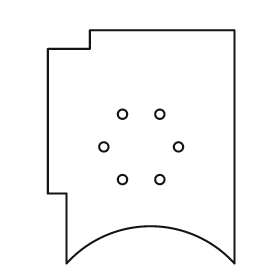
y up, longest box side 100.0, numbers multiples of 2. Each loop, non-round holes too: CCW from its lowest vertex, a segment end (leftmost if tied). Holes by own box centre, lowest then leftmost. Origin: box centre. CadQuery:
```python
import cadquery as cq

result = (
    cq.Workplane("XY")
    .moveTo(-32.0, -50.0)
    .threePointArc((4.0, -34.0), (40.0, -50.0))
    .lineTo(40.0, 50.0)
    .lineTo(-22.0, 50.0)
    .lineTo(-22.0, 42.0)
    .lineTo(-40.0, 42.0)
    .lineTo(-40.0, -20.0)
    .lineTo(-32.0, -20.0)
    .close()
    .moveTo(-8.0, -14.0)
    .circle(2.0)
    .moveTo(8.0, -14.0)
    .circle(2.0)
    .moveTo(-16.0, 0.0)
    .circle(2.0)
    .moveTo(16.0, 0.0)
    .circle(2.0)
    .moveTo(-8.0, 14.0)
    .circle(2.0)
    .moveTo(8.0, 14.0)
    .circle(2.0)
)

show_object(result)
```